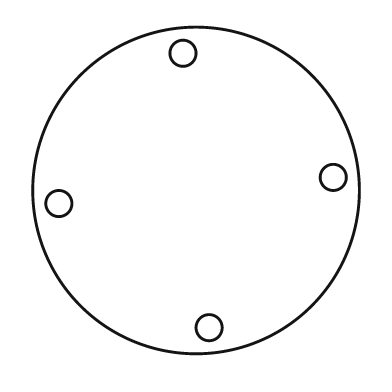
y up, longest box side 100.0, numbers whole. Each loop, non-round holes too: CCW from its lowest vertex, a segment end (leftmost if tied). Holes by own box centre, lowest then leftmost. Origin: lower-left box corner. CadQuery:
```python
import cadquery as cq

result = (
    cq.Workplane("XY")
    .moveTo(50.0, 50.0)
    .circle(50.0)
    .moveTo(54.0, 8.0)
    .circle(4.0)
    .moveTo(8.0, 46.0)
    .circle(4.0)
    .moveTo(92.0, 54.0)
    .circle(4.0)
    .moveTo(46.0, 92.0)
    .circle(4.0)
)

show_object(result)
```